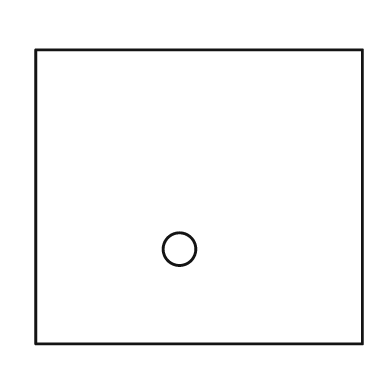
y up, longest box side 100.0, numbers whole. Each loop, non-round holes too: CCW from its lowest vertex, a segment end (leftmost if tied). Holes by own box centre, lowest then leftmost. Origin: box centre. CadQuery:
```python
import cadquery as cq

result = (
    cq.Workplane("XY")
    .moveTo(-50.0, -45.0)
    .lineTo(50.0, -45.0)
    .lineTo(50.0, 45.0)
    .lineTo(-50.0, 45.0)
    .close()
    .moveTo(-6.0, -16.0)
    .circle(5.0)
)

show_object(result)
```